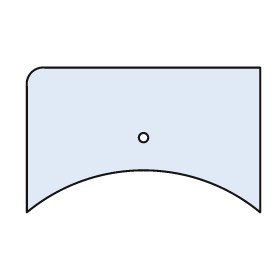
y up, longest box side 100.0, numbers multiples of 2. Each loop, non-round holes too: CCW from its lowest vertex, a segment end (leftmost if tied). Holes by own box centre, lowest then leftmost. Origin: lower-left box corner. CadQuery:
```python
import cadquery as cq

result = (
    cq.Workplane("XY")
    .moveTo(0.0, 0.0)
    .threePointArc((50.0, 18.0), (100.0, 0.0))
    .lineTo(100.0, 62.0)
    .lineTo(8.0, 62.0)
    .threePointArc((2.0, 60.0), (0.0, 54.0))
    .close()
    .moveTo(50.0, 32.0)
    .circle(2.0)
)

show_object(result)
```